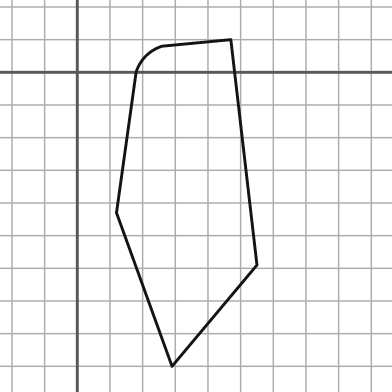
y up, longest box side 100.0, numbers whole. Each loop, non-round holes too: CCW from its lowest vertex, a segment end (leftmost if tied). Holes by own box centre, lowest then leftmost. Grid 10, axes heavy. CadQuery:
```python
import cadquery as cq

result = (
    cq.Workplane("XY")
    .moveTo(29.0, -90.0)
    .lineTo(55.0, -59.0)
    .lineTo(47.0, 10.0)
    .lineTo(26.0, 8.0)
    .threePointArc((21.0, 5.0), (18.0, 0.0))
    .lineTo(12.0, -43.0)
    .close()
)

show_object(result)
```